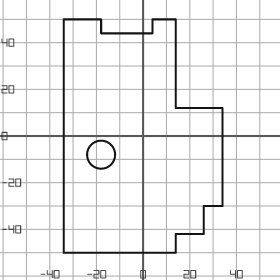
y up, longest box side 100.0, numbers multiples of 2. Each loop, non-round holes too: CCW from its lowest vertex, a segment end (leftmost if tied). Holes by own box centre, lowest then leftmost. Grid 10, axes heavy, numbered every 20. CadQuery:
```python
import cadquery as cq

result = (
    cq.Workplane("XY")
    .moveTo(-34.0, -50.0)
    .lineTo(14.0, -50.0)
    .lineTo(14.0, -42.0)
    .lineTo(26.0, -42.0)
    .lineTo(26.0, -30.0)
    .lineTo(34.0, -30.0)
    .lineTo(34.0, 12.0)
    .lineTo(14.0, 12.0)
    .lineTo(14.0, 50.0)
    .lineTo(4.0, 50.0)
    .lineTo(4.0, 44.0)
    .lineTo(-18.0, 44.0)
    .lineTo(-18.0, 50.0)
    .lineTo(-34.0, 50.0)
    .close()
    .moveTo(-18.0, -8.0)
    .circle(6.0)
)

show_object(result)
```